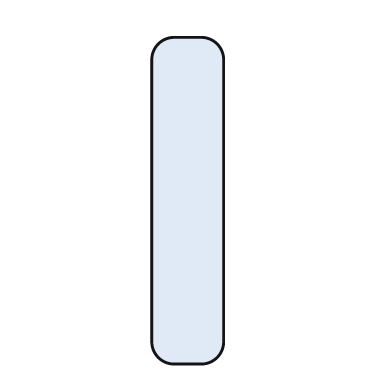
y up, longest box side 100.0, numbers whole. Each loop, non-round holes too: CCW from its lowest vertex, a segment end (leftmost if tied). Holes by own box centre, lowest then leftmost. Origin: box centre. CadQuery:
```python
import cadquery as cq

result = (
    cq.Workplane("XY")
    .moveTo(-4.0, -50.0)
    .lineTo(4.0, -50.0)
    .threePointArc((9.0, -48.0), (11.0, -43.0))
    .lineTo(11.0, 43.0)
    .threePointArc((9.0, 48.0), (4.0, 50.0))
    .lineTo(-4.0, 50.0)
    .threePointArc((-9.0, 48.0), (-11.0, 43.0))
    .lineTo(-11.0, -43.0)
    .threePointArc((-9.0, -48.0), (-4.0, -50.0))
    .close()
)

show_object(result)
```